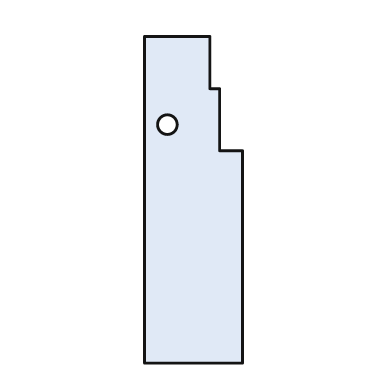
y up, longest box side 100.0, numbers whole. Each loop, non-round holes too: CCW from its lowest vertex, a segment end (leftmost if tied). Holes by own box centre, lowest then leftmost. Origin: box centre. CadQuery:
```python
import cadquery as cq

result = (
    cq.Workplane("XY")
    .moveTo(-15.0, -50.0)
    .lineTo(15.0, -50.0)
    .lineTo(15.0, 15.0)
    .lineTo(8.0, 15.0)
    .lineTo(8.0, 34.0)
    .lineTo(5.0, 34.0)
    .lineTo(5.0, 50.0)
    .lineTo(-15.0, 50.0)
    .close()
    .moveTo(-8.0, 23.0)
    .circle(3.0)
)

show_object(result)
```